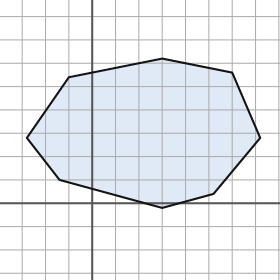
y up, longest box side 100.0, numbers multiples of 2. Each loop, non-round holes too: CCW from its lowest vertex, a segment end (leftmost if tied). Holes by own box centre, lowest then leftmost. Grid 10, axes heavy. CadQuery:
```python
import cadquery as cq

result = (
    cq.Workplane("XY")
    .moveTo(30.0, -2.0)
    .lineTo(52.0, 4.0)
    .lineTo(72.0, 28.0)
    .lineTo(60.0, 56.0)
    .lineTo(30.0, 62.0)
    .lineTo(-10.0, 54.0)
    .lineTo(-28.0, 28.0)
    .lineTo(-14.0, 10.0)
    .close()
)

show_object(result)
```